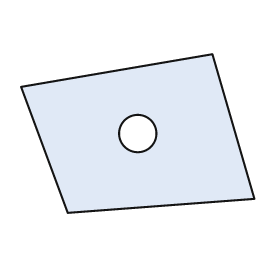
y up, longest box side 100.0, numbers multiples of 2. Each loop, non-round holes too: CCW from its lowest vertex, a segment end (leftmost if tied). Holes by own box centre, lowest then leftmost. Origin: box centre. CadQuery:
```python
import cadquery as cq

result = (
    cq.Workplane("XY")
    .moveTo(-30.0, -34.0)
    .lineTo(50.0, -28.0)
    .lineTo(32.0, 34.0)
    .lineTo(-50.0, 20.0)
    .close()
    .moveTo(0.0, 0.0)
    .circle(8.0)
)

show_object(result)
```